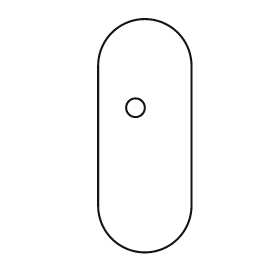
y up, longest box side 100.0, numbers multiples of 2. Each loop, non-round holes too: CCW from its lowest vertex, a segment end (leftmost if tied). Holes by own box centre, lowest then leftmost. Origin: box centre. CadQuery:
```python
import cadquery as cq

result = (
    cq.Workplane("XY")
    .moveTo(-20.0, -30.0)
    .threePointArc((0.0, -50.0), (20.0, -30.0))
    .lineTo(20.0, 30.0)
    .threePointArc((0.0, 50.0), (-20.0, 30.0))
    .close()
    .moveTo(-4.0, 12.0)
    .circle(4.0)
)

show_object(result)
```